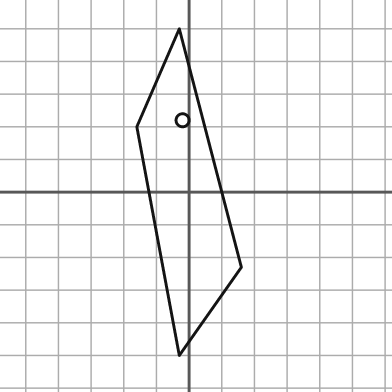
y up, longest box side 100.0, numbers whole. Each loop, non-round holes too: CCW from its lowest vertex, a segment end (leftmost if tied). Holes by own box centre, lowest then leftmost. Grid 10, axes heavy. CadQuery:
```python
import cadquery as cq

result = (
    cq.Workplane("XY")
    .moveTo(-3.0, -50.0)
    .lineTo(16.0, -23.0)
    .lineTo(-3.0, 50.0)
    .lineTo(-16.0, 20.0)
    .close()
    .moveTo(-2.0, 22.0)
    .circle(2.0)
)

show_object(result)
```